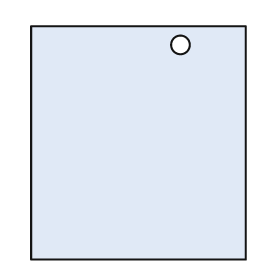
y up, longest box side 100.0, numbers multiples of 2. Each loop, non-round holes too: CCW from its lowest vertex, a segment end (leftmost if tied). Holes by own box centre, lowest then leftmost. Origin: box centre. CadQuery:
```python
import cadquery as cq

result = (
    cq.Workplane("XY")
    .moveTo(-46.0, -50.0)
    .lineTo(46.0, -50.0)
    .lineTo(46.0, 50.0)
    .lineTo(-46.0, 50.0)
    .close()
    .moveTo(18.0, 42.0)
    .circle(4.0)
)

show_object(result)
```